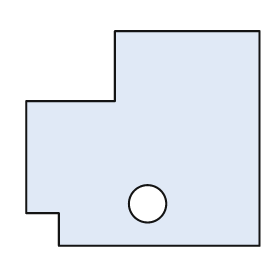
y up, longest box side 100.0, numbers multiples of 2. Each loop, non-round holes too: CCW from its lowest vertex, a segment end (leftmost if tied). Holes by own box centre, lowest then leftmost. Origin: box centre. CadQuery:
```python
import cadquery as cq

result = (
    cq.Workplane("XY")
    .moveTo(-36.0, -46.0)
    .lineTo(50.0, -46.0)
    .lineTo(50.0, 46.0)
    .lineTo(-12.0, 46.0)
    .lineTo(-12.0, 16.0)
    .lineTo(-50.0, 16.0)
    .lineTo(-50.0, -32.0)
    .lineTo(-36.0, -32.0)
    .close()
    .moveTo(2.0, -28.0)
    .circle(8.0)
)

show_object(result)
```